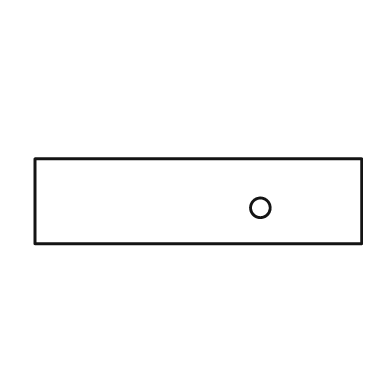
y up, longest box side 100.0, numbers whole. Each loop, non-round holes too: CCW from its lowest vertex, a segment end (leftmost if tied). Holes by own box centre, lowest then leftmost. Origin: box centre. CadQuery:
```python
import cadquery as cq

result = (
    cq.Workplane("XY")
    .moveTo(-50.0, -13.0)
    .lineTo(50.0, -13.0)
    .lineTo(50.0, 13.0)
    .lineTo(-50.0, 13.0)
    .close()
    .moveTo(19.0, -2.0)
    .circle(3.0)
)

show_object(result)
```